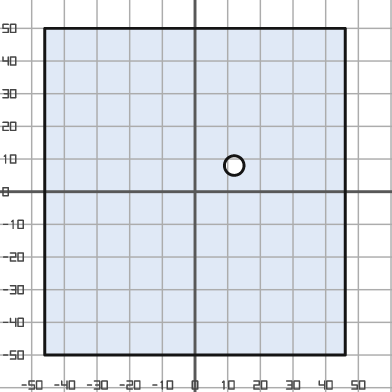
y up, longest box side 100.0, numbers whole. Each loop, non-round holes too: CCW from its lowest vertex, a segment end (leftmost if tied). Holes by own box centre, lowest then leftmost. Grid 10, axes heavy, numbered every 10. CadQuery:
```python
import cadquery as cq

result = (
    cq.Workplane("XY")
    .moveTo(-46.0, -50.0)
    .lineTo(46.0, -50.0)
    .lineTo(46.0, 50.0)
    .lineTo(-46.0, 50.0)
    .close()
    .moveTo(12.0, 8.0)
    .circle(3.0)
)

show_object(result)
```